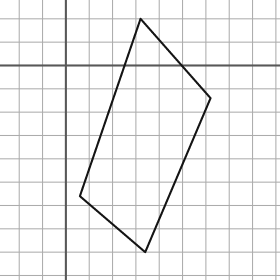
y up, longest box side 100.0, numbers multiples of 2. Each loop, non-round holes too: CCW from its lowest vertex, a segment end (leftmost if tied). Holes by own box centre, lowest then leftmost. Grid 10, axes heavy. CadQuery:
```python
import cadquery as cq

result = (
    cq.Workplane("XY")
    .moveTo(34.0, -80.0)
    .lineTo(62.0, -14.0)
    .lineTo(32.0, 20.0)
    .lineTo(6.0, -56.0)
    .close()
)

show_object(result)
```